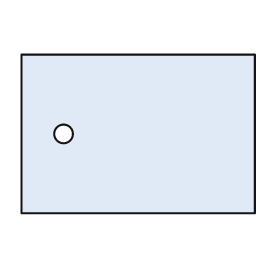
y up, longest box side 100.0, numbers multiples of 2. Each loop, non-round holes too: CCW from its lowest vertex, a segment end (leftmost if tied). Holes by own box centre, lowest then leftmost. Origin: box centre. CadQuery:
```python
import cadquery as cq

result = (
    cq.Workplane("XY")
    .moveTo(-50.0, -34.0)
    .lineTo(50.0, -34.0)
    .lineTo(50.0, 34.0)
    .lineTo(-50.0, 34.0)
    .close()
    .moveTo(-32.0, 0.0)
    .circle(4.0)
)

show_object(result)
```